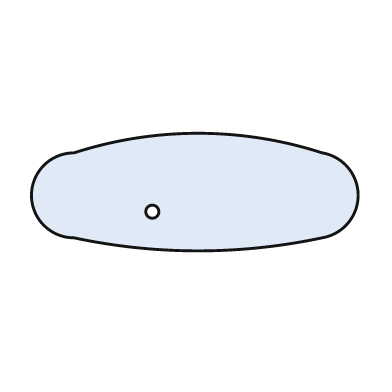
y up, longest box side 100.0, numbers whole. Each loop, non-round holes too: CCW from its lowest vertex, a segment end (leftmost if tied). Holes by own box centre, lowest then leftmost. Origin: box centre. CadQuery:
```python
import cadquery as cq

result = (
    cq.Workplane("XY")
    .moveTo(-37.0, -14.0)
    .threePointArc((1.0, -18.0), (39.0, -14.0))
    .threePointArc((50.0, -1.0), (39.0, 12.0))
    .threePointArc((1.0, 18.0), (-37.0, 12.0))
    .threePointArc((-50.0, -1.0), (-37.0, -14.0))
    .close()
    .moveTo(-13.0, -6.0)
    .circle(2.0)
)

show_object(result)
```